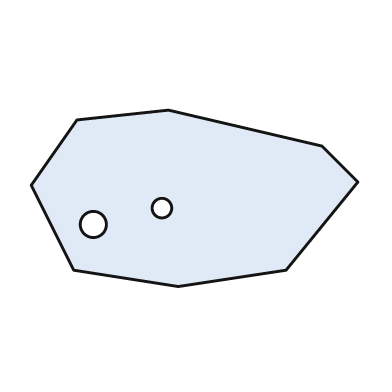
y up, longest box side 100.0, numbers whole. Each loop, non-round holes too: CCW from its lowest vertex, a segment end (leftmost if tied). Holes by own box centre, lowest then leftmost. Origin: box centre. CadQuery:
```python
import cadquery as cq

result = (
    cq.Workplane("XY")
    .moveTo(-5.0, -27.0)
    .lineTo(28.0, -22.0)
    .lineTo(50.0, 5.0)
    .lineTo(39.0, 16.0)
    .lineTo(-8.0, 27.0)
    .lineTo(-36.0, 24.0)
    .lineTo(-50.0, 4.0)
    .lineTo(-37.0, -22.0)
    .close()
    .moveTo(-31.0, -8.0)
    .circle(4.0)
    .moveTo(-10.0, -3.0)
    .circle(3.0)
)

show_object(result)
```